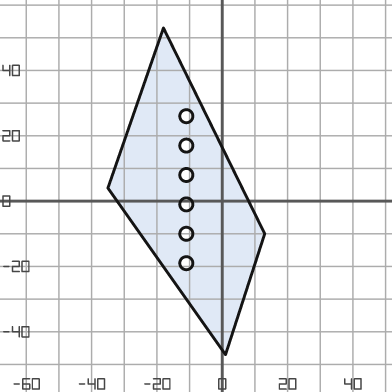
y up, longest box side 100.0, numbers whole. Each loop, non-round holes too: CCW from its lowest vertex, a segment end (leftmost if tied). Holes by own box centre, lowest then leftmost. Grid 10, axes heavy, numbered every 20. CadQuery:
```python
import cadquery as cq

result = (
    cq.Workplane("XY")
    .moveTo(1.0, -47.0)
    .lineTo(13.0, -10.0)
    .lineTo(-18.0, 53.0)
    .lineTo(-35.0, 4.0)
    .close()
    .moveTo(-11.0, -19.0)
    .circle(2.0)
    .moveTo(-11.0, -10.0)
    .circle(2.0)
    .moveTo(-11.0, -1.0)
    .circle(2.0)
    .moveTo(-11.0, 8.0)
    .circle(2.0)
    .moveTo(-11.0, 17.0)
    .circle(2.0)
    .moveTo(-11.0, 26.0)
    .circle(2.0)
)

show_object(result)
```